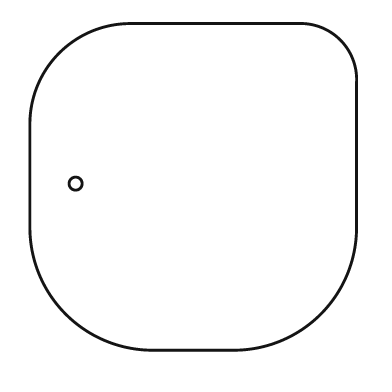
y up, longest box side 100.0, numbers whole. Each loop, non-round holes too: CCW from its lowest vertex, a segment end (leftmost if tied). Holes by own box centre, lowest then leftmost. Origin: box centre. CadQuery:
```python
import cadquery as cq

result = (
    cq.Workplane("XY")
    .moveTo(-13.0, -50.0)
    .lineTo(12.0, -50.0)
    .threePointArc((39.0, -39.0), (50.0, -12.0))
    .lineTo(50.0, 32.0)
    .threePointArc((45.0, 45.0), (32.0, 50.0))
    .lineTo(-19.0, 50.0)
    .threePointArc((-41.0, 41.0), (-50.0, 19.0))
    .lineTo(-50.0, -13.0)
    .threePointArc((-39.0, -39.0), (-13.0, -50.0))
    .close()
    .moveTo(-36.0, 1.0)
    .circle(2.0)
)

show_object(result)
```